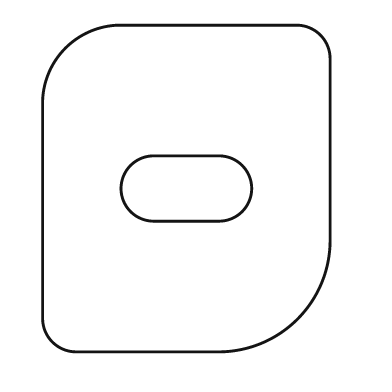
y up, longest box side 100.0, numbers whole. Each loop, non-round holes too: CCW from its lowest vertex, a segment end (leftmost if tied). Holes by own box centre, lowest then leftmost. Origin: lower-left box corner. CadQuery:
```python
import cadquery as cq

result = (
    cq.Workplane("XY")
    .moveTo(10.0, 0.0)
    .lineTo(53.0, 0.0)
    .threePointArc((78.0, 10.0), (88.0, 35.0))
    .lineTo(88.0, 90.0)
    .threePointArc((85.0, 97.0), (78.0, 100.0))
    .lineTo(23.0, 100.0)
    .threePointArc((7.0, 93.0), (0.0, 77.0))
    .lineTo(0.0, 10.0)
    .threePointArc((3.0, 3.0), (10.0, 0.0))
    .close()
    .moveTo(34.0, 40.0)
    .lineTo(54.0, 40.0)
    .threePointArc((64.0, 50.0), (54.0, 60.0))
    .lineTo(34.0, 60.0)
    .threePointArc((24.0, 50.0), (34.0, 40.0))
    .close()
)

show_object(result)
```